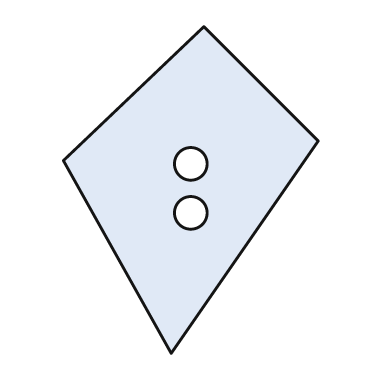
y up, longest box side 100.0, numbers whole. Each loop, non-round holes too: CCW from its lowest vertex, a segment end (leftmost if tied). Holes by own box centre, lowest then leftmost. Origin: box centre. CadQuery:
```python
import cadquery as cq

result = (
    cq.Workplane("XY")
    .moveTo(-6.0, -50.0)
    .lineTo(39.0, 15.0)
    .lineTo(4.0, 50.0)
    .lineTo(-39.0, 9.0)
    .close()
    .moveTo(0.0, -7.0)
    .circle(5.0)
    .moveTo(0.0, 8.0)
    .circle(5.0)
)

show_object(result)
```